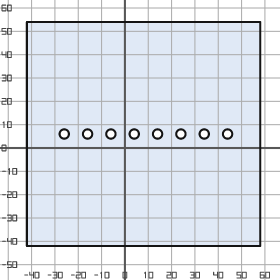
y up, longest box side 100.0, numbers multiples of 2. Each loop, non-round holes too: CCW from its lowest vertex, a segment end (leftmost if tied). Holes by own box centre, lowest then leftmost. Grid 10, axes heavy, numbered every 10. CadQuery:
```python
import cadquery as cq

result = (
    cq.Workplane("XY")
    .moveTo(-42.0, -42.0)
    .lineTo(58.0, -42.0)
    .lineTo(58.0, 54.0)
    .lineTo(-42.0, 54.0)
    .close()
    .moveTo(-26.0, 6.0)
    .circle(2.0)
    .moveTo(-16.0, 6.0)
    .circle(2.0)
    .moveTo(-6.0, 6.0)
    .circle(2.0)
    .moveTo(4.0, 6.0)
    .circle(2.0)
    .moveTo(14.0, 6.0)
    .circle(2.0)
    .moveTo(24.0, 6.0)
    .circle(2.0)
    .moveTo(34.0, 6.0)
    .circle(2.0)
    .moveTo(44.0, 6.0)
    .circle(2.0)
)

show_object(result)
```